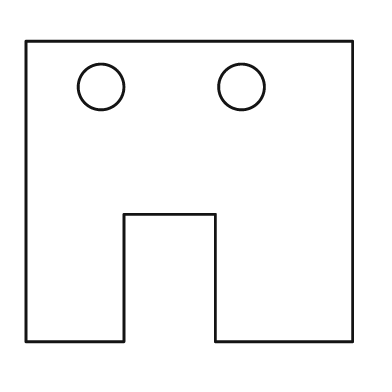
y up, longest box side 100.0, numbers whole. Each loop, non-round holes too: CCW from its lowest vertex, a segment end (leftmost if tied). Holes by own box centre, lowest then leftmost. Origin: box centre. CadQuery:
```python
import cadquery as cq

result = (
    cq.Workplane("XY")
    .moveTo(-50.0, -46.0)
    .lineTo(-20.0, -46.0)
    .lineTo(-20.0, -7.0)
    .lineTo(8.0, -7.0)
    .lineTo(8.0, -46.0)
    .lineTo(50.0, -46.0)
    .lineTo(50.0, 46.0)
    .lineTo(-50.0, 46.0)
    .close()
    .moveTo(-27.0, 32.0)
    .circle(7.0)
    .moveTo(16.0, 32.0)
    .circle(7.0)
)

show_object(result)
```